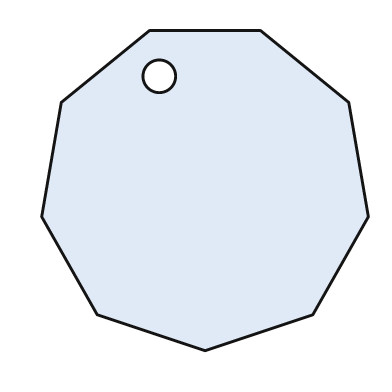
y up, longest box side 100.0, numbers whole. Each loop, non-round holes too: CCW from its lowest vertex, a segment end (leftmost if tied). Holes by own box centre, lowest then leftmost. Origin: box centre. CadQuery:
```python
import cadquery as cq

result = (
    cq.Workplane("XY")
    .moveTo(0.0, -49.0)
    .lineTo(33.0, -38.0)
    .lineTo(50.0, -8.0)
    .lineTo(44.0, 27.0)
    .lineTo(17.0, 49.0)
    .lineTo(-17.0, 49.0)
    .lineTo(-44.0, 27.0)
    .lineTo(-50.0, -8.0)
    .lineTo(-33.0, -38.0)
    .close()
    .moveTo(-14.0, 35.0)
    .circle(5.0)
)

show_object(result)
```